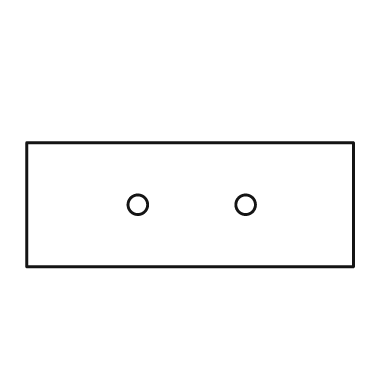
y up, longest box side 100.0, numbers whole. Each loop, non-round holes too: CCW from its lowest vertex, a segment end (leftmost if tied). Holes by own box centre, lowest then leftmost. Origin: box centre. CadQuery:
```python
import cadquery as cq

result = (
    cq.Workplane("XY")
    .moveTo(-50.0, -19.0)
    .lineTo(50.0, -19.0)
    .lineTo(50.0, 19.0)
    .lineTo(-50.0, 19.0)
    .close()
    .moveTo(-16.0, 0.0)
    .circle(3.0)
    .moveTo(17.0, 0.0)
    .circle(3.0)
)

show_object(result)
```